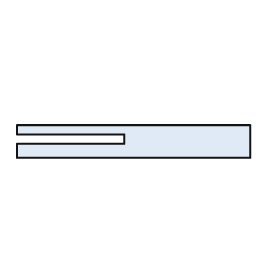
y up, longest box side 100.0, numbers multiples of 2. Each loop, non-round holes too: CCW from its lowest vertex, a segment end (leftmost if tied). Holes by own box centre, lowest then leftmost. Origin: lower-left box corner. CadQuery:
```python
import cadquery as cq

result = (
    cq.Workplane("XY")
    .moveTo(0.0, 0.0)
    .lineTo(100.0, 0.0)
    .lineTo(100.0, 14.0)
    .lineTo(0.0, 14.0)
    .lineTo(0.0, 10.0)
    .lineTo(46.0, 10.0)
    .lineTo(46.0, 6.0)
    .lineTo(0.0, 6.0)
    .close()
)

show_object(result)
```